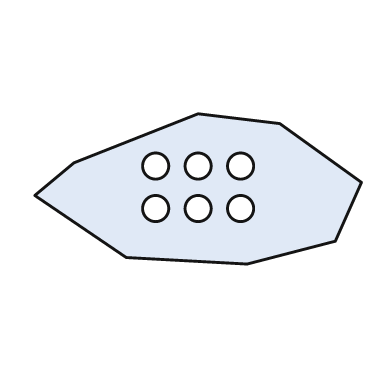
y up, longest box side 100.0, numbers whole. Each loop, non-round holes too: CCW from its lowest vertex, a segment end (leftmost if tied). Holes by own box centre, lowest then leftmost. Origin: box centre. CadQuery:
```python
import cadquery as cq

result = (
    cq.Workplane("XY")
    .moveTo(15.0, -23.0)
    .lineTo(42.0, -16.0)
    .lineTo(50.0, 2.0)
    .lineTo(25.0, 20.0)
    .lineTo(0.0, 23.0)
    .lineTo(-38.0, 8.0)
    .lineTo(-50.0, -2.0)
    .lineTo(-22.0, -21.0)
    .close()
    .moveTo(-13.0, -6.0)
    .circle(4.0)
    .moveTo(0.0, -6.0)
    .circle(4.0)
    .moveTo(13.0, -6.0)
    .circle(4.0)
    .moveTo(-13.0, 7.0)
    .circle(4.0)
    .moveTo(0.0, 7.0)
    .circle(4.0)
    .moveTo(13.0, 7.0)
    .circle(4.0)
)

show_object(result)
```